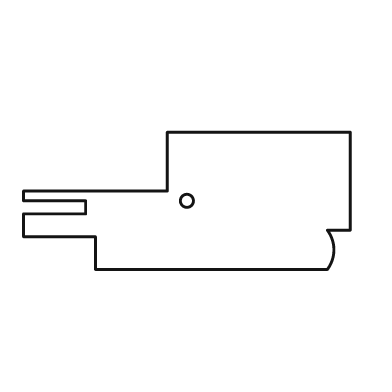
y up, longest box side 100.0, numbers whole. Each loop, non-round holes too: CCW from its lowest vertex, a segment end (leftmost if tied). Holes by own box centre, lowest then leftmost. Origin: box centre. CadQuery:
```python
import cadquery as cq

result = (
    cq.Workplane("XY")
    .moveTo(-28.0, -21.0)
    .lineTo(43.0, -21.0)
    .threePointArc((45.0, -15.0), (43.0, -9.0))
    .lineTo(50.0, -9.0)
    .lineTo(50.0, 21.0)
    .lineTo(-6.0, 21.0)
    .lineTo(-6.0, 3.0)
    .lineTo(-50.0, 3.0)
    .lineTo(-50.0, 0.0)
    .lineTo(-31.0, 0.0)
    .lineTo(-31.0, -4.0)
    .lineTo(-50.0, -4.0)
    .lineTo(-50.0, -11.0)
    .lineTo(-28.0, -11.0)
    .close()
    .moveTo(0.0, 0.0)
    .circle(2.0)
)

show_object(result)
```